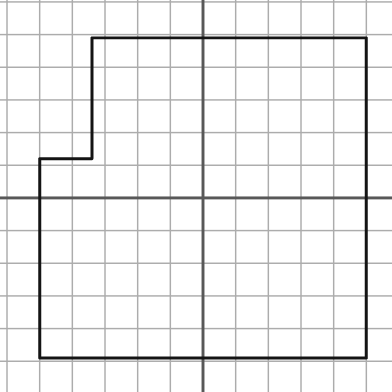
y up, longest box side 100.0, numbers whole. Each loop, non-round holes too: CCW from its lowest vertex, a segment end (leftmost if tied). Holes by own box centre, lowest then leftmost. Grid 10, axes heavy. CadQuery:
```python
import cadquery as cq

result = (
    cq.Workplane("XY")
    .moveTo(-50.0, -49.0)
    .lineTo(50.0, -49.0)
    .lineTo(50.0, 49.0)
    .lineTo(-34.0, 49.0)
    .lineTo(-34.0, 12.0)
    .lineTo(-50.0, 12.0)
    .close()
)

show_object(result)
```